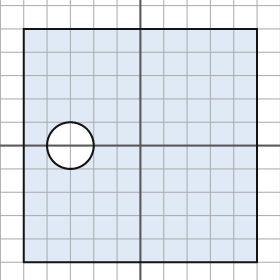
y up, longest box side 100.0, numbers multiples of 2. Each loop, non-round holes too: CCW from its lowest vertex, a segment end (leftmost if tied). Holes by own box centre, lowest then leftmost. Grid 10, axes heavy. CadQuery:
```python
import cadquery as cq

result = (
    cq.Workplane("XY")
    .moveTo(-50.0, -50.0)
    .lineTo(50.0, -50.0)
    .lineTo(50.0, 50.0)
    .lineTo(-50.0, 50.0)
    .close()
    .moveTo(-30.0, 0.0)
    .circle(10.0)
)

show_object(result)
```